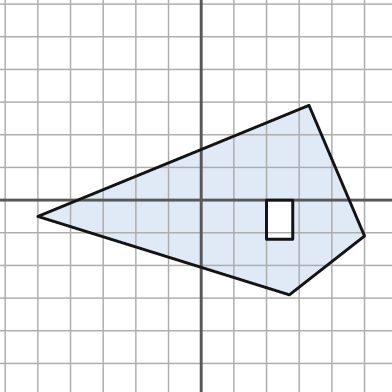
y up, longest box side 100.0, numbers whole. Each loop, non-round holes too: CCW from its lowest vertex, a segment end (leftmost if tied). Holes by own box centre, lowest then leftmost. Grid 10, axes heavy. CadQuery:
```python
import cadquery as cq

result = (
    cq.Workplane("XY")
    .moveTo(27.0, -29.0)
    .lineTo(50.0, -11.0)
    .lineTo(33.0, 29.0)
    .lineTo(-50.0, -5.0)
    .close()
    .moveTo(20.0, -12.0)
    .lineTo(28.0, -12.0)
    .lineTo(28.0, 0.0)
    .lineTo(20.0, 0.0)
    .close()
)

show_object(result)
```